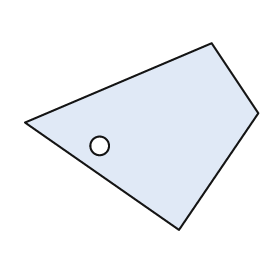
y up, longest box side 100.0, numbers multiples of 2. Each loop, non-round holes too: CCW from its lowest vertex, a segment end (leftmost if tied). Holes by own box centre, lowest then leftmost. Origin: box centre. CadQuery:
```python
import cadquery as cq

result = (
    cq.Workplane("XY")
    .moveTo(16.0, -40.0)
    .lineTo(50.0, 10.0)
    .lineTo(30.0, 40.0)
    .lineTo(-50.0, 6.0)
    .close()
    .moveTo(-18.0, -4.0)
    .circle(4.0)
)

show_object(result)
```